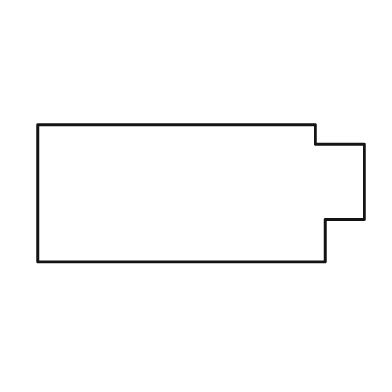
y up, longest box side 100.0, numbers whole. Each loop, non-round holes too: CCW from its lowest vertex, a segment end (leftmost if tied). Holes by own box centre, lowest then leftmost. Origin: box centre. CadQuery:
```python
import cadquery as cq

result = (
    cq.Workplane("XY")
    .moveTo(-50.0, -21.0)
    .lineTo(38.0, -21.0)
    .lineTo(38.0, -8.0)
    .lineTo(50.0, -8.0)
    .lineTo(50.0, 15.0)
    .lineTo(35.0, 15.0)
    .lineTo(35.0, 21.0)
    .lineTo(-50.0, 21.0)
    .close()
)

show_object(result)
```